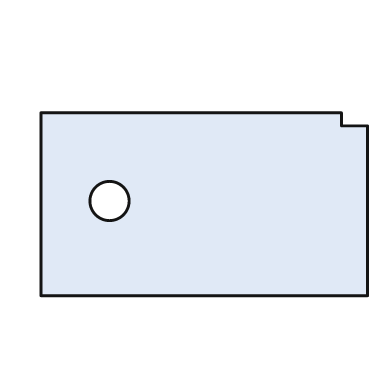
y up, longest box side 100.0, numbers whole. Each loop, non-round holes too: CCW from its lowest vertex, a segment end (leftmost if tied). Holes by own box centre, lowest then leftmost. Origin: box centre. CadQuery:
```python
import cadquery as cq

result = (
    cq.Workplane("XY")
    .moveTo(-50.0, -28.0)
    .lineTo(50.0, -28.0)
    .lineTo(50.0, 24.0)
    .lineTo(42.0, 24.0)
    .lineTo(42.0, 28.0)
    .lineTo(-50.0, 28.0)
    .close()
    .moveTo(-29.0, 1.0)
    .circle(6.0)
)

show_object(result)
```